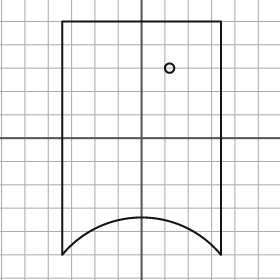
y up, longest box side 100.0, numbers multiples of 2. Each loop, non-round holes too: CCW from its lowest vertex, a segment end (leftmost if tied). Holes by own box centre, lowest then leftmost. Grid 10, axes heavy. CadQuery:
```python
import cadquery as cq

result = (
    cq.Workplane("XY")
    .moveTo(-34.0, -50.0)
    .threePointArc((0.0, -34.0), (34.0, -50.0))
    .lineTo(34.0, 50.0)
    .lineTo(-34.0, 50.0)
    .close()
    .moveTo(12.0, 30.0)
    .circle(2.0)
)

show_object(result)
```